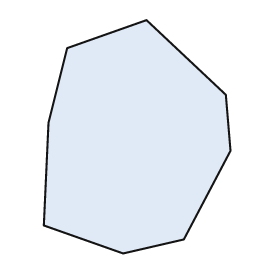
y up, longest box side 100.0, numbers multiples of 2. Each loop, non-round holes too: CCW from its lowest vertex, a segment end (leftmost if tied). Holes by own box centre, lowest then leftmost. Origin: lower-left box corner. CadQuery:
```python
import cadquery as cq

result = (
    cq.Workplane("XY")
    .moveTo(34.0, 0.0)
    .lineTo(60.0, 6.0)
    .lineTo(80.0, 44.0)
    .lineTo(78.0, 68.0)
    .lineTo(44.0, 100.0)
    .lineTo(10.0, 88.0)
    .lineTo(2.0, 56.0)
    .lineTo(0.0, 12.0)
    .close()
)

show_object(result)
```